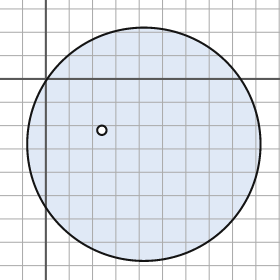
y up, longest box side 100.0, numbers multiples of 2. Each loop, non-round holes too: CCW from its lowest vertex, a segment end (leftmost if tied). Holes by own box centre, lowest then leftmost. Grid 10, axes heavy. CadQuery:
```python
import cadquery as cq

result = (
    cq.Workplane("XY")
    .moveTo(42.0, -28.0)
    .circle(50.0)
    .moveTo(24.0, -22.0)
    .circle(2.0)
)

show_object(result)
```